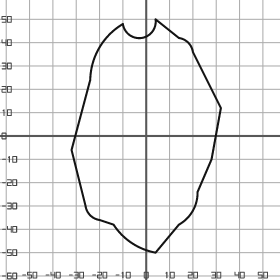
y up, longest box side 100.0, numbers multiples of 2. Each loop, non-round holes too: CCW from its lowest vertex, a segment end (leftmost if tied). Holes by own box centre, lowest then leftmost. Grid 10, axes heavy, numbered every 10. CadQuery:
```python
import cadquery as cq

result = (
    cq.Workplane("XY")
    .moveTo(4.0, -50.0)
    .lineTo(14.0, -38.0)
    .threePointArc((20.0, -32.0), (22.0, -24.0))
    .lineTo(28.0, -10.0)
    .lineTo(32.0, 12.0)
    .lineTo(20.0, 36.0)
    .threePointArc((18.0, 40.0), (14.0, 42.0))
    .lineTo(4.0, 50.0)
    .threePointArc((-2.0, 42.0), (-10.0, 48.0))
    .threePointArc((-20.0, 38.0), (-24.0, 24.0))
    .lineTo(-32.0, -6.0)
    .lineTo(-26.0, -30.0)
    .threePointArc((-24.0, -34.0), (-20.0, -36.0))
    .lineTo(-14.0, -38.0)
    .threePointArc((-6.0, -46.0), (4.0, -50.0))
    .close()
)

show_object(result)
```